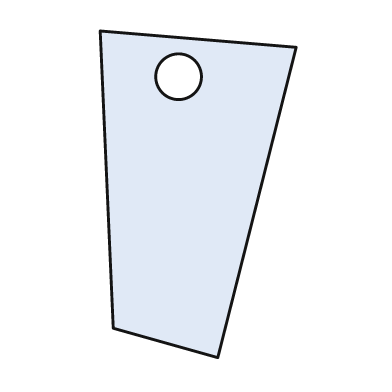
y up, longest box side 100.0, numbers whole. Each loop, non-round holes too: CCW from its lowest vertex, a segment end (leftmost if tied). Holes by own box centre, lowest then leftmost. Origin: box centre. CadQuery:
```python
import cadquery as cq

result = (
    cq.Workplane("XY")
    .moveTo(6.0, -50.0)
    .lineTo(30.0, 45.0)
    .lineTo(-30.0, 50.0)
    .lineTo(-26.0, -41.0)
    .close()
    .moveTo(-6.0, 36.0)
    .circle(7.0)
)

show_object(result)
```